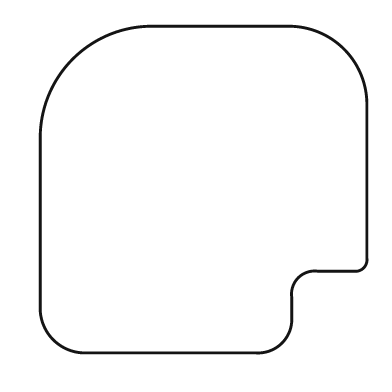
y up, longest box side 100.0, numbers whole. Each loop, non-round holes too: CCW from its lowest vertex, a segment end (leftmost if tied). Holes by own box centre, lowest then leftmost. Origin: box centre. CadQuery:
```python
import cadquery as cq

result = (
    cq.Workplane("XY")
    .moveTo(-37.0, -50.0)
    .lineTo(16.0, -50.0)
    .threePointArc((24.0, -47.0), (27.0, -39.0))
    .lineTo(27.0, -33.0)
    .threePointArc((29.0, -27.0), (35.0, -25.0))
    .lineTo(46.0, -25.0)
    .threePointArc((49.0, -24.0), (50.0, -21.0))
    .lineTo(50.0, 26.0)
    .threePointArc((43.0, 43.0), (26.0, 50.0))
    .lineTo(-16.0, 50.0)
    .threePointArc((-40.0, 40.0), (-50.0, 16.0))
    .lineTo(-50.0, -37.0)
    .threePointArc((-46.0, -46.0), (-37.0, -50.0))
    .close()
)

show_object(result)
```